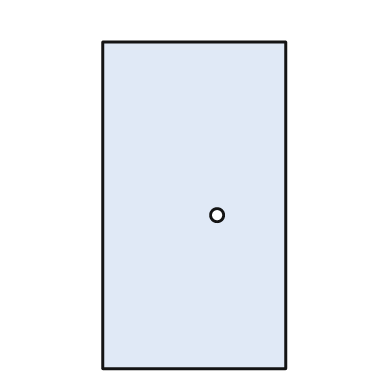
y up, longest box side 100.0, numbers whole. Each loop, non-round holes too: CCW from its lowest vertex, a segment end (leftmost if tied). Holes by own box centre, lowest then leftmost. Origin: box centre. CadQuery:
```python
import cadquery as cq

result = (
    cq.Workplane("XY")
    .moveTo(-28.0, -50.0)
    .lineTo(28.0, -50.0)
    .lineTo(28.0, 50.0)
    .lineTo(-28.0, 50.0)
    .close()
    .moveTo(7.0, -3.0)
    .circle(2.0)
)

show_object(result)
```